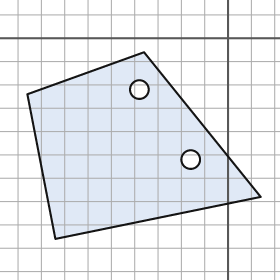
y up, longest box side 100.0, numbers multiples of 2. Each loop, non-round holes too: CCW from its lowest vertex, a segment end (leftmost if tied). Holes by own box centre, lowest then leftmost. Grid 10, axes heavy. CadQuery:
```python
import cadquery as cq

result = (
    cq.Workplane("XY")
    .moveTo(-74.0, -86.0)
    .lineTo(14.0, -68.0)
    .lineTo(-36.0, -6.0)
    .lineTo(-86.0, -24.0)
    .close()
    .moveTo(-16.0, -52.0)
    .circle(4.0)
    .moveTo(-38.0, -22.0)
    .circle(4.0)
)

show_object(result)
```